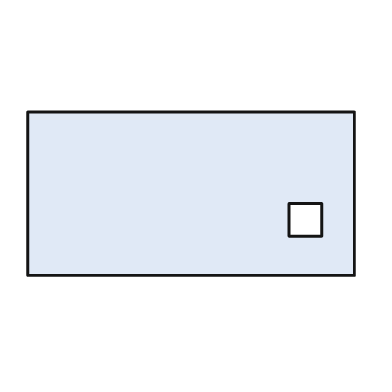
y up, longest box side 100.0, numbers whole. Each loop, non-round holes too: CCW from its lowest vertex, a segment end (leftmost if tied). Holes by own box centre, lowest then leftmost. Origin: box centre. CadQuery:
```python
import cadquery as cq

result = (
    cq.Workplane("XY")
    .moveTo(-50.0, -25.0)
    .lineTo(50.0, -25.0)
    .lineTo(50.0, 25.0)
    .lineTo(-50.0, 25.0)
    .close()
    .moveTo(30.0, -13.0)
    .lineTo(40.0, -13.0)
    .lineTo(40.0, -3.0)
    .lineTo(30.0, -3.0)
    .close()
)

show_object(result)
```